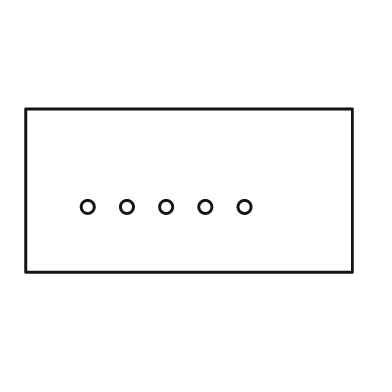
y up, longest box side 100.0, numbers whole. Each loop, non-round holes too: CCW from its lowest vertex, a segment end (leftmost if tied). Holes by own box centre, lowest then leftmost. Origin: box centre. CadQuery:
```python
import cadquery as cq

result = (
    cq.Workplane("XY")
    .moveTo(-50.0, -25.0)
    .lineTo(50.0, -25.0)
    .lineTo(50.0, 25.0)
    .lineTo(-50.0, 25.0)
    .close()
    .moveTo(-31.0, -5.0)
    .circle(2.0)
    .moveTo(-19.0, -5.0)
    .circle(2.0)
    .moveTo(-7.0, -5.0)
    .circle(2.0)
    .moveTo(5.0, -5.0)
    .circle(2.0)
    .moveTo(17.0, -5.0)
    .circle(2.0)
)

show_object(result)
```